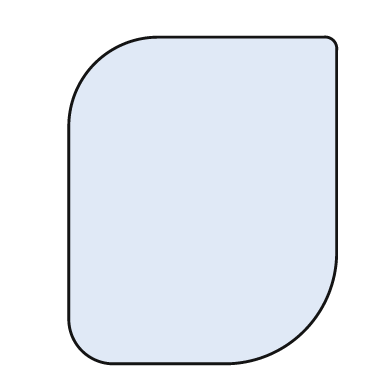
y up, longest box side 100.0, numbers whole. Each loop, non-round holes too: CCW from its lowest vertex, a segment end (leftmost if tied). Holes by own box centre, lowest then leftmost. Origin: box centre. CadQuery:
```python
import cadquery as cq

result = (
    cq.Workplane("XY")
    .moveTo(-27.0, -50.0)
    .lineTo(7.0, -50.0)
    .threePointArc((31.0, -40.0), (41.0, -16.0))
    .lineTo(41.0, 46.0)
    .threePointArc((40.0, 49.0), (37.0, 50.0))
    .lineTo(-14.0, 50.0)
    .threePointArc((-33.0, 42.0), (-41.0, 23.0))
    .lineTo(-41.0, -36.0)
    .threePointArc((-37.0, -46.0), (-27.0, -50.0))
    .close()
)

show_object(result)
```